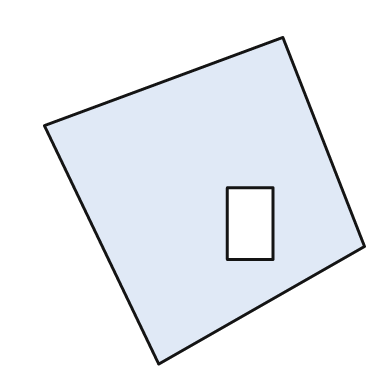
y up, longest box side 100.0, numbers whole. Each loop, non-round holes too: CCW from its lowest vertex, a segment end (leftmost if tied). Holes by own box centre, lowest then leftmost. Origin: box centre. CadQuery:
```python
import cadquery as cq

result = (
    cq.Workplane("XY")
    .moveTo(-14.0, -50.0)
    .lineTo(49.0, -14.0)
    .lineTo(24.0, 50.0)
    .lineTo(-49.0, 23.0)
    .close()
    .moveTo(7.0, -18.0)
    .lineTo(21.0, -18.0)
    .lineTo(21.0, 4.0)
    .lineTo(7.0, 4.0)
    .close()
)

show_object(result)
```